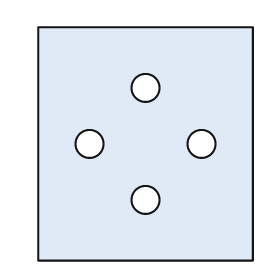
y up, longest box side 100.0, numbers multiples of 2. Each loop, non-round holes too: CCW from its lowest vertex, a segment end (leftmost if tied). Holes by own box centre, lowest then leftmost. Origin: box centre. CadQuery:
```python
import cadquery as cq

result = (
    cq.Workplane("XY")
    .moveTo(-46.0, -50.0)
    .lineTo(46.0, -50.0)
    .lineTo(46.0, 50.0)
    .lineTo(-46.0, 50.0)
    .close()
    .moveTo(0.0, -24.0)
    .circle(6.0)
    .moveTo(-24.0, 0.0)
    .circle(6.0)
    .moveTo(24.0, 0.0)
    .circle(6.0)
    .moveTo(0.0, 24.0)
    .circle(6.0)
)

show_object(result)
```